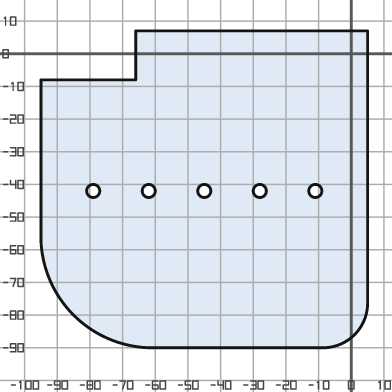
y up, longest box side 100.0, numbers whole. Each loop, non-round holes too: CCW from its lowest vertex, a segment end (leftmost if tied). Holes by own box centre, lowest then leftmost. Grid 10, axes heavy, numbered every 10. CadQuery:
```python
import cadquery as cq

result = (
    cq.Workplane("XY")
    .moveTo(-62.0, -90.0)
    .lineTo(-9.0, -90.0)
    .threePointArc((1.0, -86.0), (5.0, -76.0))
    .lineTo(5.0, 7.0)
    .lineTo(-66.0, 7.0)
    .lineTo(-66.0, -8.0)
    .lineTo(-95.0, -8.0)
    .lineTo(-95.0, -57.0)
    .threePointArc((-85.0, -80.0), (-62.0, -90.0))
    .close()
    .moveTo(-79.0, -42.0)
    .circle(2.0)
    .moveTo(-62.0, -42.0)
    .circle(2.0)
    .moveTo(-45.0, -42.0)
    .circle(2.0)
    .moveTo(-28.0, -42.0)
    .circle(2.0)
    .moveTo(-11.0, -42.0)
    .circle(2.0)
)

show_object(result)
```